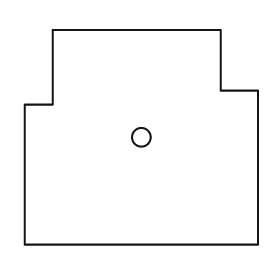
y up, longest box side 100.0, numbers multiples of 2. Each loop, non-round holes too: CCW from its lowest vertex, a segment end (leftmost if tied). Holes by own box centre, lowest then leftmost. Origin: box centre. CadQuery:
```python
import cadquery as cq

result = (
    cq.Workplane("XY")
    .moveTo(-50.0, -46.0)
    .lineTo(50.0, -46.0)
    .lineTo(50.0, 20.0)
    .lineTo(34.0, 20.0)
    .lineTo(34.0, 46.0)
    .lineTo(-38.0, 46.0)
    .lineTo(-38.0, 14.0)
    .lineTo(-50.0, 14.0)
    .close()
    .moveTo(0.0, 0.0)
    .circle(4.0)
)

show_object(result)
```